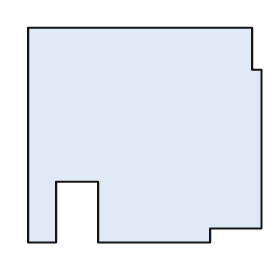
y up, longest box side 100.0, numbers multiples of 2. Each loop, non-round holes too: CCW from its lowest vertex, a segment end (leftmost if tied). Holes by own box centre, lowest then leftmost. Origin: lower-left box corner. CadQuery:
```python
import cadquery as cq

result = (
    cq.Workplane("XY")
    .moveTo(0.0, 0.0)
    .lineTo(12.0, 0.0)
    .lineTo(12.0, 26.0)
    .lineTo(30.0, 26.0)
    .lineTo(30.0, 0.0)
    .lineTo(78.0, 0.0)
    .lineTo(78.0, 6.0)
    .lineTo(100.0, 6.0)
    .lineTo(100.0, 74.0)
    .lineTo(96.0, 74.0)
    .lineTo(96.0, 92.0)
    .lineTo(0.0, 92.0)
    .close()
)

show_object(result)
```